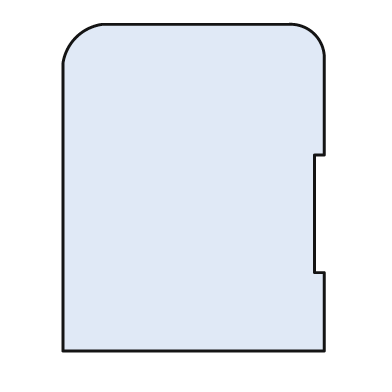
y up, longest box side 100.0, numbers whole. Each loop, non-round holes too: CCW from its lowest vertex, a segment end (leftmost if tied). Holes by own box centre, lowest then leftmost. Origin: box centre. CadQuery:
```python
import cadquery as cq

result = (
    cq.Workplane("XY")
    .moveTo(-40.0, -50.0)
    .lineTo(40.0, -50.0)
    .lineTo(40.0, -26.0)
    .lineTo(37.0, -26.0)
    .lineTo(37.0, 10.0)
    .lineTo(40.0, 10.0)
    .lineTo(40.0, 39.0)
    .threePointArc((37.0, 47.0), (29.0, 50.0))
    .lineTo(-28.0, 50.0)
    .threePointArc((-36.0, 46.0), (-40.0, 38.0))
    .close()
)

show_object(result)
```